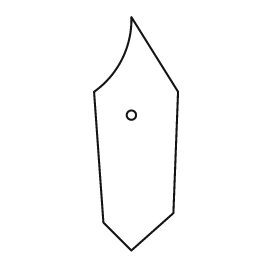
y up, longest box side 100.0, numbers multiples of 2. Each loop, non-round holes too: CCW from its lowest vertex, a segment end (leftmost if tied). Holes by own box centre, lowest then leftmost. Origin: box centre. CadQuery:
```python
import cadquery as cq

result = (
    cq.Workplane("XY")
    .moveTo(-2.0, -50.0)
    .lineTo(16.0, -34.0)
    .lineTo(18.0, 18.0)
    .lineTo(-2.0, 50.0)
    .threePointArc((-6.0, 32.0), (-18.0, 18.0))
    .lineTo(-14.0, -38.0)
    .close()
    .moveTo(-2.0, 8.0)
    .circle(2.0)
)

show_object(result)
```